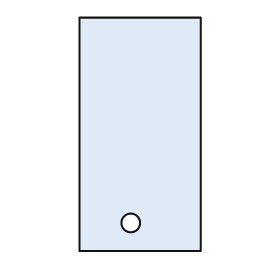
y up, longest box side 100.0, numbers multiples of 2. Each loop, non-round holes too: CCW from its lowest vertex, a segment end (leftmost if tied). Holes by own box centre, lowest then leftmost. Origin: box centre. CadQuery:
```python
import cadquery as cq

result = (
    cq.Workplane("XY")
    .moveTo(-26.0, -50.0)
    .lineTo(26.0, -50.0)
    .lineTo(26.0, 50.0)
    .lineTo(-26.0, 50.0)
    .close()
    .moveTo(-4.0, -38.0)
    .circle(4.0)
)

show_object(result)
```